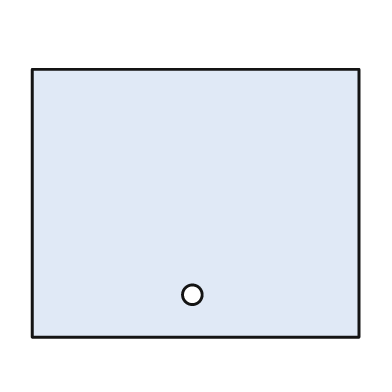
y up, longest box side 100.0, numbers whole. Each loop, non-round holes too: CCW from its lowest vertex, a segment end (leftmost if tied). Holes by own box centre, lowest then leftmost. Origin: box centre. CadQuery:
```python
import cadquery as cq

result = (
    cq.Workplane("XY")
    .moveTo(-50.0, -41.0)
    .lineTo(50.0, -41.0)
    .lineTo(50.0, 41.0)
    .lineTo(-50.0, 41.0)
    .close()
    .moveTo(-1.0, -28.0)
    .circle(3.0)
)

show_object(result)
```